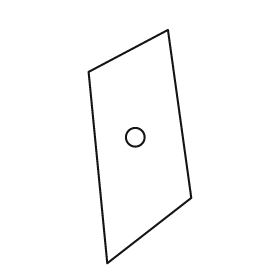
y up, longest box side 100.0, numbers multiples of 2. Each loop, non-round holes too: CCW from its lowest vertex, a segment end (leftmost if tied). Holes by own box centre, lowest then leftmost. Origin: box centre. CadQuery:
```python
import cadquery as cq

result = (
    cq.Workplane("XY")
    .moveTo(-14.0, -50.0)
    .lineTo(22.0, -22.0)
    .lineTo(12.0, 50.0)
    .lineTo(-22.0, 32.0)
    .close()
    .moveTo(-2.0, 4.0)
    .circle(4.0)
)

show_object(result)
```